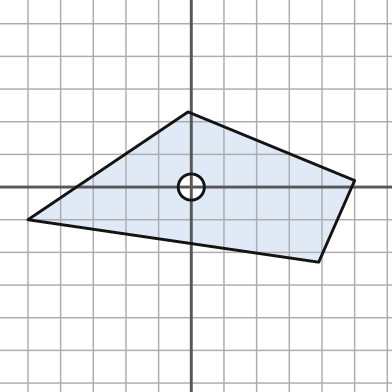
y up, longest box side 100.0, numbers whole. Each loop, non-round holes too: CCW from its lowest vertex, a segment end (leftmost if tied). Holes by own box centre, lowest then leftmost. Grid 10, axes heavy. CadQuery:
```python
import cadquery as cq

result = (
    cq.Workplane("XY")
    .moveTo(39.0, -23.0)
    .lineTo(50.0, 2.0)
    .lineTo(-1.0, 23.0)
    .lineTo(-50.0, -10.0)
    .close()
    .moveTo(0.0, 0.0)
    .circle(4.0)
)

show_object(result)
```